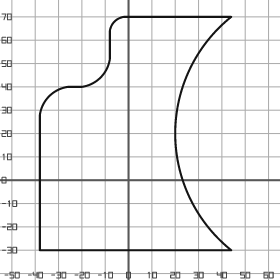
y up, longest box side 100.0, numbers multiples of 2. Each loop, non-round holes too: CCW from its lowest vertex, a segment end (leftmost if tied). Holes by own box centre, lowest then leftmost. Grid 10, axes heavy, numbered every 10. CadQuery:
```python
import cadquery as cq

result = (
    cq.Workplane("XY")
    .moveTo(-38.0, -30.0)
    .lineTo(44.0, -30.0)
    .threePointArc((20.0, 20.0), (44.0, 70.0))
    .lineTo(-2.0, 70.0)
    .threePointArc((-6.0, 68.0), (-8.0, 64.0))
    .lineTo(-8.0, 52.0)
    .threePointArc((-12.0, 44.0), (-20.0, 40.0))
    .lineTo(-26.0, 40.0)
    .threePointArc((-34.0, 36.0), (-38.0, 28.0))
    .close()
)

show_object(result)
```